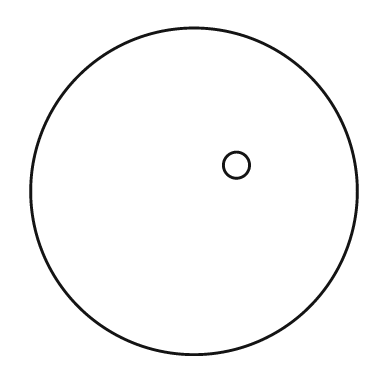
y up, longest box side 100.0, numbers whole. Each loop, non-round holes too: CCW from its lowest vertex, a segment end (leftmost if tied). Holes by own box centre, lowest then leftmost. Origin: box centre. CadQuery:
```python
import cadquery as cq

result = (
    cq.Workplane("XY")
    .moveTo(0.0, 0.0)
    .circle(50.0)
    .moveTo(13.0, 8.0)
    .circle(4.0)
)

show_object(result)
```